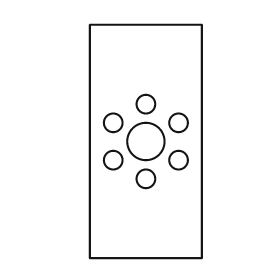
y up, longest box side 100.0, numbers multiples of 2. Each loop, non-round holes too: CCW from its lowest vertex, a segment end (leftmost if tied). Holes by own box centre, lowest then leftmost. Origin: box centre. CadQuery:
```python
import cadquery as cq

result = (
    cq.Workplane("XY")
    .moveTo(-24.0, -50.0)
    .lineTo(24.0, -50.0)
    .lineTo(24.0, 50.0)
    .lineTo(-24.0, 50.0)
    .close()
    .moveTo(0.0, -16.0)
    .circle(4.0)
    .moveTo(-14.0, -8.0)
    .circle(4.0)
    .moveTo(14.0, -8.0)
    .circle(4.0)
    .moveTo(0.0, 0.0)
    .circle(8.0)
    .moveTo(-14.0, 8.0)
    .circle(4.0)
    .moveTo(14.0, 8.0)
    .circle(4.0)
    .moveTo(0.0, 16.0)
    .circle(4.0)
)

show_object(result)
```